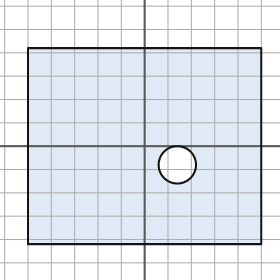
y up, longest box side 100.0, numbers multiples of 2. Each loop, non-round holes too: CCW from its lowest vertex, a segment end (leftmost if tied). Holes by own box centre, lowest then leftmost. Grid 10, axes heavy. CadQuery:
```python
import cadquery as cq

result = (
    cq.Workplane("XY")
    .moveTo(-50.0, -42.0)
    .lineTo(50.0, -42.0)
    .lineTo(50.0, 42.0)
    .lineTo(-50.0, 42.0)
    .close()
    .moveTo(14.0, -8.0)
    .circle(8.0)
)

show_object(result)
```